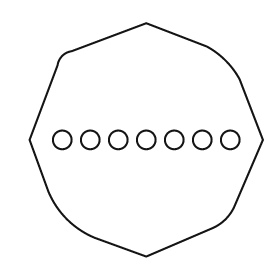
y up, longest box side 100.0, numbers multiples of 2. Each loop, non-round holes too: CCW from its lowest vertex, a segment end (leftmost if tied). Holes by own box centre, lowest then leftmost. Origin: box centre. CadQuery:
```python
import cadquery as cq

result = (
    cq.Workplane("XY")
    .moveTo(0.0, -50.0)
    .lineTo(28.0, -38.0)
    .threePointArc((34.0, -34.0), (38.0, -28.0))
    .lineTo(50.0, 0.0)
    .lineTo(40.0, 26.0)
    .threePointArc((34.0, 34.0), (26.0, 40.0))
    .lineTo(0.0, 50.0)
    .lineTo(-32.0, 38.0)
    .threePointArc((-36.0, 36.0), (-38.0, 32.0))
    .lineTo(-50.0, 0.0)
    .lineTo(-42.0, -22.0)
    .threePointArc((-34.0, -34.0), (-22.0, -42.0))
    .close()
    .moveTo(-36.0, 0.0)
    .circle(4.0)
    .moveTo(-24.0, 0.0)
    .circle(4.0)
    .moveTo(-12.0, 0.0)
    .circle(4.0)
    .moveTo(0.0, 0.0)
    .circle(4.0)
    .moveTo(12.0, 0.0)
    .circle(4.0)
    .moveTo(24.0, 0.0)
    .circle(4.0)
    .moveTo(36.0, 0.0)
    .circle(4.0)
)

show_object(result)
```